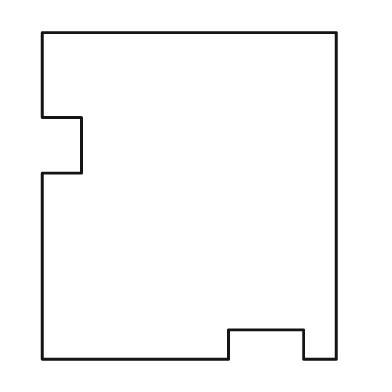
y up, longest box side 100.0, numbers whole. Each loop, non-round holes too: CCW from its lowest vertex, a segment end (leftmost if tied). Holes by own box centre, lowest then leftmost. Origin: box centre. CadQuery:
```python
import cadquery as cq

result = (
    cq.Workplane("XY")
    .moveTo(-45.0, -50.0)
    .lineTo(12.0, -50.0)
    .lineTo(12.0, -41.0)
    .lineTo(35.0, -41.0)
    .lineTo(35.0, -50.0)
    .lineTo(45.0, -50.0)
    .lineTo(45.0, 50.0)
    .lineTo(-45.0, 50.0)
    .lineTo(-45.0, 24.0)
    .lineTo(-33.0, 24.0)
    .lineTo(-33.0, 7.0)
    .lineTo(-45.0, 7.0)
    .close()
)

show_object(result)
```